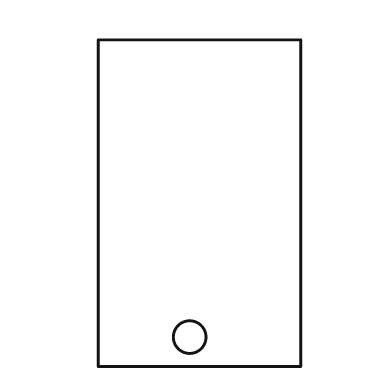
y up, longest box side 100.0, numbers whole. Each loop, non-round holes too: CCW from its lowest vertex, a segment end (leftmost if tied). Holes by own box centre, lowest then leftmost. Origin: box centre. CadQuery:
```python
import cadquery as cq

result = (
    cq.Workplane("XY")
    .moveTo(-31.0, -50.0)
    .lineTo(31.0, -50.0)
    .lineTo(31.0, 50.0)
    .lineTo(-31.0, 50.0)
    .close()
    .moveTo(-3.0, -41.0)
    .circle(5.0)
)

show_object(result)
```